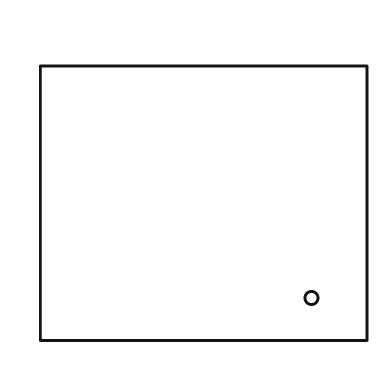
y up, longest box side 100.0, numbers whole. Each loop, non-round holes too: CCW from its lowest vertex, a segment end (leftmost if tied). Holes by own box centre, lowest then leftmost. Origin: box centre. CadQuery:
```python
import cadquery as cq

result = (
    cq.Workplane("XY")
    .moveTo(-50.0, -42.0)
    .lineTo(50.0, -42.0)
    .lineTo(50.0, 42.0)
    .lineTo(-50.0, 42.0)
    .close()
    .moveTo(33.0, -29.0)
    .circle(2.0)
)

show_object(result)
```